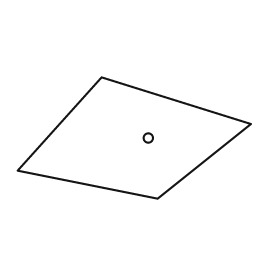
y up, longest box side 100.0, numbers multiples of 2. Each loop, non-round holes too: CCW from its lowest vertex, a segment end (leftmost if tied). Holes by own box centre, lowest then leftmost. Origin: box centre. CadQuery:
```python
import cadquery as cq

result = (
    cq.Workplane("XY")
    .moveTo(10.0, -26.0)
    .lineTo(50.0, 6.0)
    .lineTo(-14.0, 26.0)
    .lineTo(-50.0, -14.0)
    .close()
    .moveTo(6.0, 0.0)
    .circle(2.0)
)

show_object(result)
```